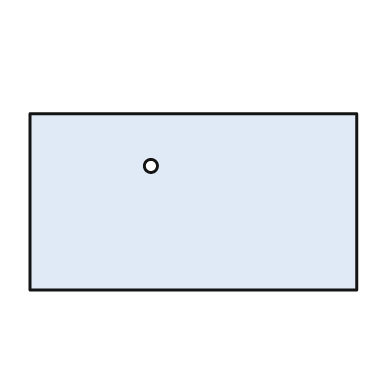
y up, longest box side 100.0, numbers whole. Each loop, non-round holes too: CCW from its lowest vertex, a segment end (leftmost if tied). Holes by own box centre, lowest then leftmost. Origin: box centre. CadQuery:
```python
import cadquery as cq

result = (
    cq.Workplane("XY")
    .moveTo(-50.0, -27.0)
    .lineTo(50.0, -27.0)
    .lineTo(50.0, 27.0)
    .lineTo(-50.0, 27.0)
    .close()
    .moveTo(-13.0, 11.0)
    .circle(2.0)
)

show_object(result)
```